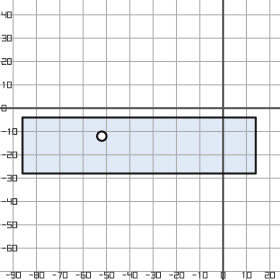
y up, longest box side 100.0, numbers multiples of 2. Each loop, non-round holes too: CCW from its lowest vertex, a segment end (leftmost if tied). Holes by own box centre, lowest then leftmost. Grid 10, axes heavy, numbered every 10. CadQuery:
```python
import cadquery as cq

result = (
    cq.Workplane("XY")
    .moveTo(-86.0, -28.0)
    .lineTo(14.0, -28.0)
    .lineTo(14.0, -4.0)
    .lineTo(-86.0, -4.0)
    .close()
    .moveTo(-52.0, -12.0)
    .circle(2.0)
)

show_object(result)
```